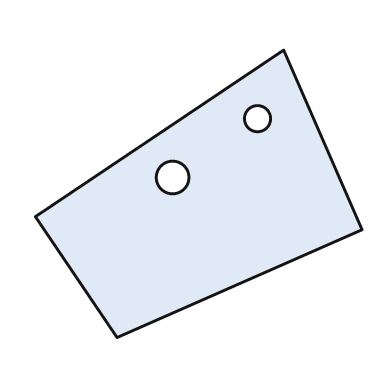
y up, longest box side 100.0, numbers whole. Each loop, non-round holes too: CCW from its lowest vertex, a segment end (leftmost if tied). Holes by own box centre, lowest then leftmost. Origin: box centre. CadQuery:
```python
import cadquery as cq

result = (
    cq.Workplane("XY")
    .moveTo(-25.0, -44.0)
    .lineTo(50.0, -11.0)
    .lineTo(26.0, 44.0)
    .lineTo(-50.0, -7.0)
    .close()
    .moveTo(-8.0, 5.0)
    .circle(5.0)
    .moveTo(18.0, 23.0)
    .circle(4.0)
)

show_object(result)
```